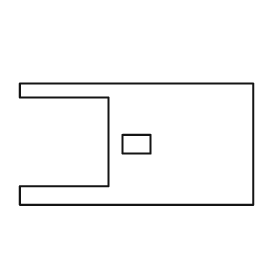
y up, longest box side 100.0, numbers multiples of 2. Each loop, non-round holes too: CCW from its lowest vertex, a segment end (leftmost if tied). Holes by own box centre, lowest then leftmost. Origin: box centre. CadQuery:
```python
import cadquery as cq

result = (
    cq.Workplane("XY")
    .moveTo(-50.0, -26.0)
    .lineTo(50.0, -26.0)
    .lineTo(50.0, 26.0)
    .lineTo(-50.0, 26.0)
    .lineTo(-50.0, 20.0)
    .lineTo(-12.0, 20.0)
    .lineTo(-12.0, -18.0)
    .lineTo(-50.0, -18.0)
    .close()
    .moveTo(-6.0, -4.0)
    .lineTo(6.0, -4.0)
    .lineTo(6.0, 4.0)
    .lineTo(-6.0, 4.0)
    .close()
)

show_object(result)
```